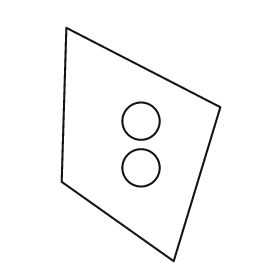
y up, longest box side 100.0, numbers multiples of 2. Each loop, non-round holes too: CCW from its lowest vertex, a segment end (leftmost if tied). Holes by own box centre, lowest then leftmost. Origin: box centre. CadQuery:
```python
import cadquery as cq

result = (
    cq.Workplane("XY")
    .moveTo(14.0, -50.0)
    .lineTo(34.0, 16.0)
    .lineTo(-32.0, 50.0)
    .lineTo(-34.0, -16.0)
    .close()
    .moveTo(0.0, -10.0)
    .circle(8.0)
    .moveTo(0.0, 10.0)
    .circle(8.0)
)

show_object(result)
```